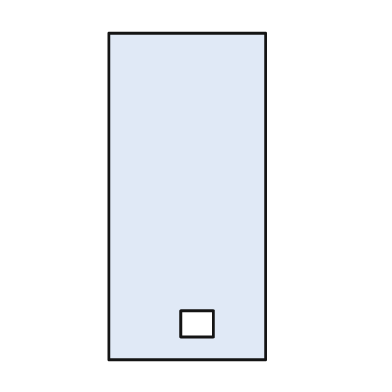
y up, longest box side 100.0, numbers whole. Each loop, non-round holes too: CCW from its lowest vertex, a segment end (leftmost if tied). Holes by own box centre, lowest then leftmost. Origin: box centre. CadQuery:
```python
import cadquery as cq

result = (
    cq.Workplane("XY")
    .moveTo(-24.0, -50.0)
    .lineTo(24.0, -50.0)
    .lineTo(24.0, 50.0)
    .lineTo(-24.0, 50.0)
    .close()
    .moveTo(-2.0, -43.0)
    .lineTo(8.0, -43.0)
    .lineTo(8.0, -35.0)
    .lineTo(-2.0, -35.0)
    .close()
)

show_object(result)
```